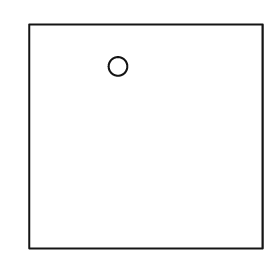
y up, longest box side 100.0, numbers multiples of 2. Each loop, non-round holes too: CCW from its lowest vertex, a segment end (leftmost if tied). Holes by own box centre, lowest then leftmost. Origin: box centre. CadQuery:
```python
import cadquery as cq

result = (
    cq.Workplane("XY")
    .moveTo(-50.0, -48.0)
    .lineTo(50.0, -48.0)
    .lineTo(50.0, 48.0)
    .lineTo(-50.0, 48.0)
    .close()
    .moveTo(-12.0, 30.0)
    .circle(4.0)
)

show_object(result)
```